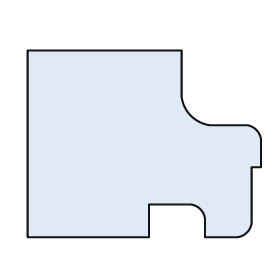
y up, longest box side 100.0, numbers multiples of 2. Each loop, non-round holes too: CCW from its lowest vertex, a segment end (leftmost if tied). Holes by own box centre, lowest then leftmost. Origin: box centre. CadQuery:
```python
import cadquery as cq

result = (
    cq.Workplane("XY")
    .moveTo(-50.0, -40.0)
    .lineTo(2.0, -40.0)
    .lineTo(2.0, -26.0)
    .lineTo(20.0, -26.0)
    .threePointArc((24.0, -28.0), (26.0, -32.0))
    .lineTo(26.0, -40.0)
    .lineTo(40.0, -40.0)
    .threePointArc((44.0, -38.0), (46.0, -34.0))
    .lineTo(46.0, -10.0)
    .lineTo(50.0, -10.0)
    .lineTo(50.0, 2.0)
    .threePointArc((48.0, 6.0), (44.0, 8.0))
    .lineTo(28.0, 8.0)
    .threePointArc((20.0, 12.0), (16.0, 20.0))
    .lineTo(16.0, 40.0)
    .lineTo(-50.0, 40.0)
    .close()
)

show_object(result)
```